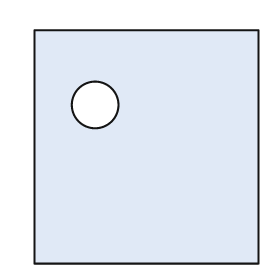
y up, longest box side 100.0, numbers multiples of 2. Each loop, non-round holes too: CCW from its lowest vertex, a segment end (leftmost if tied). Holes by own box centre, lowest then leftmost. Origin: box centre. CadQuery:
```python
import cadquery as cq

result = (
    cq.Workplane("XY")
    .moveTo(-48.0, -50.0)
    .lineTo(48.0, -50.0)
    .lineTo(48.0, 50.0)
    .lineTo(-48.0, 50.0)
    .close()
    .moveTo(-22.0, 18.0)
    .circle(10.0)
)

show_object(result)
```